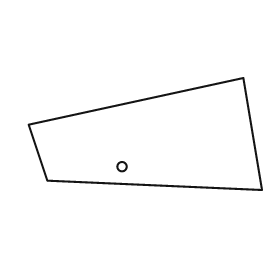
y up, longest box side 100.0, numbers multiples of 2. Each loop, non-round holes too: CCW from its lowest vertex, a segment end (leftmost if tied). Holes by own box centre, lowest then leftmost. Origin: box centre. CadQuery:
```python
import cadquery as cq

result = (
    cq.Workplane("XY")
    .moveTo(50.0, -24.0)
    .lineTo(42.0, 24.0)
    .lineTo(-50.0, 4.0)
    .lineTo(-42.0, -20.0)
    .close()
    .moveTo(-10.0, -14.0)
    .circle(2.0)
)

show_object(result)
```